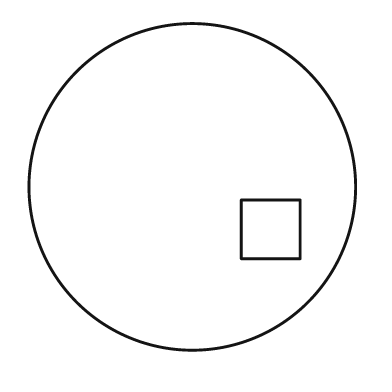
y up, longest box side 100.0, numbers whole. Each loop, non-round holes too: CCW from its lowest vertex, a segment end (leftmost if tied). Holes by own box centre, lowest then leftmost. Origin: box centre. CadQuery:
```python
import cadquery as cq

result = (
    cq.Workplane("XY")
    .moveTo(0.0, 0.0)
    .circle(50.0)
    .moveTo(15.0, -22.0)
    .lineTo(33.0, -22.0)
    .lineTo(33.0, -4.0)
    .lineTo(15.0, -4.0)
    .close()
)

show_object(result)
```